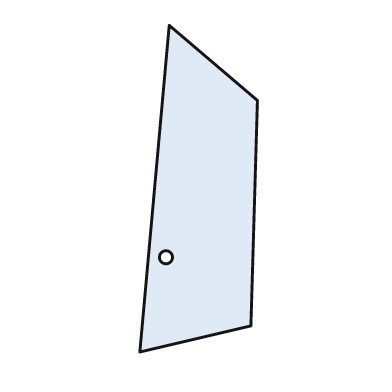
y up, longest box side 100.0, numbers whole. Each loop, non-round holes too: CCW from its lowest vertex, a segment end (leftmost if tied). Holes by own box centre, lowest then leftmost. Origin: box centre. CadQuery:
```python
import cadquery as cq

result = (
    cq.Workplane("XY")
    .moveTo(-18.0, -50.0)
    .lineTo(16.0, -42.0)
    .lineTo(18.0, 27.0)
    .lineTo(-9.0, 50.0)
    .close()
    .moveTo(-10.0, -21.0)
    .circle(2.0)
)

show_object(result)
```